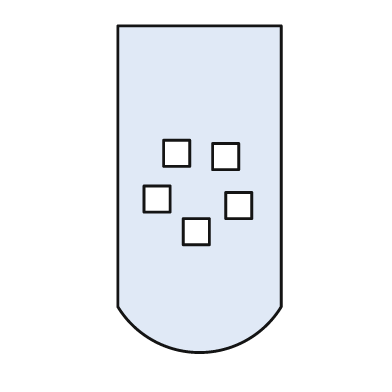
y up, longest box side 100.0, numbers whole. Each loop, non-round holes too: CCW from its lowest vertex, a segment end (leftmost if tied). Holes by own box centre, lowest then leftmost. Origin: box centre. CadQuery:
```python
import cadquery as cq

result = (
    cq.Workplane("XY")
    .moveTo(-25.0, -36.0)
    .threePointArc((0.0, -50.0), (25.0, -36.0))
    .lineTo(25.0, 50.0)
    .lineTo(-25.0, 50.0)
    .close()
    .moveTo(-5.0, -17.0)
    .lineTo(3.0, -17.0)
    .lineTo(3.0, -9.0)
    .lineTo(-5.0, -9.0)
    .close()
    .moveTo(8.0, -9.0)
    .lineTo(16.0, -9.0)
    .lineTo(16.0, -1.0)
    .lineTo(8.0, -1.0)
    .close()
    .moveTo(-17.0, -7.0)
    .lineTo(-9.0, -7.0)
    .lineTo(-9.0, 1.0)
    .lineTo(-17.0, 1.0)
    .close()
    .moveTo(4.0, 6.0)
    .lineTo(12.0, 6.0)
    .lineTo(12.0, 14.0)
    .lineTo(4.0, 14.0)
    .close()
    .moveTo(-11.0, 7.0)
    .lineTo(-3.0, 7.0)
    .lineTo(-3.0, 15.0)
    .lineTo(-11.0, 15.0)
    .close()
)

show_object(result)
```